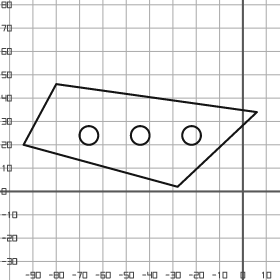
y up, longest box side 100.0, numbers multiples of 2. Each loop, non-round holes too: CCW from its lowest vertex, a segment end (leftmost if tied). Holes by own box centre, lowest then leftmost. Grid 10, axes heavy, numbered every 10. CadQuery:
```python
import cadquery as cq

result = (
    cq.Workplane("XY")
    .moveTo(-28.0, 2.0)
    .lineTo(6.0, 34.0)
    .lineTo(-80.0, 46.0)
    .lineTo(-94.0, 20.0)
    .close()
    .moveTo(-66.0, 24.0)
    .circle(4.0)
    .moveTo(-44.0, 24.0)
    .circle(4.0)
    .moveTo(-22.0, 24.0)
    .circle(4.0)
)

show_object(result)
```